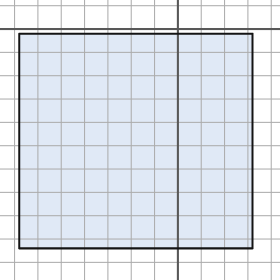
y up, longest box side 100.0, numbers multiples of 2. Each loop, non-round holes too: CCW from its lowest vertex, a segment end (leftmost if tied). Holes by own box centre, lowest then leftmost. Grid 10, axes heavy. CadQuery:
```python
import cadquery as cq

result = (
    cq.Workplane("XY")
    .moveTo(-68.0, -94.0)
    .lineTo(32.0, -94.0)
    .lineTo(32.0, -2.0)
    .lineTo(-68.0, -2.0)
    .close()
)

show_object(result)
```